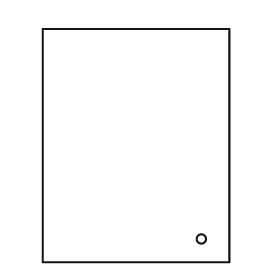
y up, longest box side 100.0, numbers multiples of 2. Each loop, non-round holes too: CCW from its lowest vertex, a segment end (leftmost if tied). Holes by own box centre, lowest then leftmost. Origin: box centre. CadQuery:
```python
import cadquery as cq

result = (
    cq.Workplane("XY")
    .moveTo(-40.0, -50.0)
    .lineTo(40.0, -50.0)
    .lineTo(40.0, 50.0)
    .lineTo(-40.0, 50.0)
    .close()
    .moveTo(28.0, -40.0)
    .circle(2.0)
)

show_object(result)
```